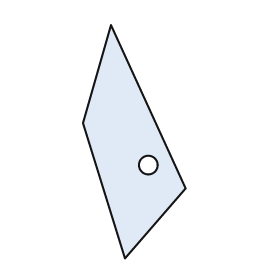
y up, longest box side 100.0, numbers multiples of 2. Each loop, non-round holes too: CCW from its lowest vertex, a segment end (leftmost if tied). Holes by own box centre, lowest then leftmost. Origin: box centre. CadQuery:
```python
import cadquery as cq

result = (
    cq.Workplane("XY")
    .moveTo(-4.0, -50.0)
    .lineTo(22.0, -20.0)
    .lineTo(-10.0, 50.0)
    .lineTo(-22.0, 8.0)
    .close()
    .moveTo(6.0, -10.0)
    .circle(4.0)
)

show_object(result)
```